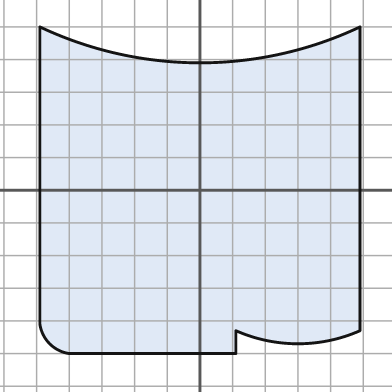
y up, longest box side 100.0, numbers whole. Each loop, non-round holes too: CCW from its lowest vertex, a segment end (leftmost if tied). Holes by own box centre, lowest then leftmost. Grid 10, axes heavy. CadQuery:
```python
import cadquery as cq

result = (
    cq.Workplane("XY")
    .moveTo(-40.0, -50.0)
    .lineTo(11.0, -50.0)
    .lineTo(11.0, -43.0)
    .threePointArc((30.0, -47.0), (49.0, -43.0))
    .lineTo(49.0, 50.0)
    .threePointArc((0.0, 39.0), (-49.0, 50.0))
    .lineTo(-49.0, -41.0)
    .threePointArc((-46.0, -47.0), (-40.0, -50.0))
    .close()
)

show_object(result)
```